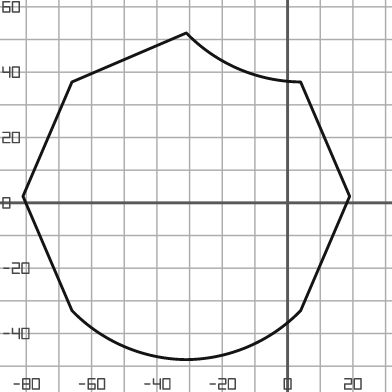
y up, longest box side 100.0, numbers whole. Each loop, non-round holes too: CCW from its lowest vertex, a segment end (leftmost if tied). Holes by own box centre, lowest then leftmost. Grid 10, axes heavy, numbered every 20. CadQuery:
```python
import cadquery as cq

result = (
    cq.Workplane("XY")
    .moveTo(-31.0, -48.0)
    .threePointArc((-12.0, -44.0), (4.0, -33.0))
    .lineTo(19.0, 2.0)
    .lineTo(4.0, 37.0)
    .threePointArc((-15.0, 41.0), (-31.0, 52.0))
    .lineTo(-66.0, 37.0)
    .lineTo(-81.0, 2.0)
    .lineTo(-66.0, -33.0)
    .threePointArc((-50.0, -44.0), (-31.0, -48.0))
    .close()
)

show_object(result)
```